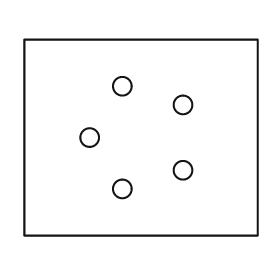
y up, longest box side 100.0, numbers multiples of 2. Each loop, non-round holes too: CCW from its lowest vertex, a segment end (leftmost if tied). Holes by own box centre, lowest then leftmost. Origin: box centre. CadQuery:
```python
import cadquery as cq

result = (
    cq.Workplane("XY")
    .moveTo(-50.0, -42.0)
    .lineTo(50.0, -42.0)
    .lineTo(50.0, 42.0)
    .lineTo(-50.0, 42.0)
    .close()
    .moveTo(-8.0, -22.0)
    .circle(4.0)
    .moveTo(18.0, -14.0)
    .circle(4.0)
    .moveTo(-22.0, 0.0)
    .circle(4.0)
    .moveTo(18.0, 14.0)
    .circle(4.0)
    .moveTo(-8.0, 22.0)
    .circle(4.0)
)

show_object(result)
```